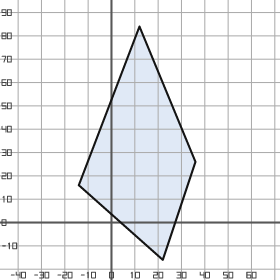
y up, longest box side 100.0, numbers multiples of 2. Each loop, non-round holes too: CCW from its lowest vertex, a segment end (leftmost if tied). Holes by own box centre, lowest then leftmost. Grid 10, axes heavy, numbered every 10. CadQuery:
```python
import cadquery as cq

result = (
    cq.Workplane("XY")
    .moveTo(22.0, -16.0)
    .lineTo(36.0, 26.0)
    .lineTo(12.0, 84.0)
    .lineTo(-14.0, 16.0)
    .close()
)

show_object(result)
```